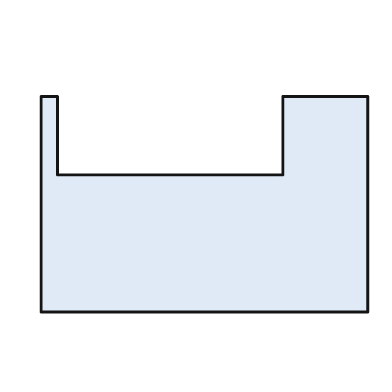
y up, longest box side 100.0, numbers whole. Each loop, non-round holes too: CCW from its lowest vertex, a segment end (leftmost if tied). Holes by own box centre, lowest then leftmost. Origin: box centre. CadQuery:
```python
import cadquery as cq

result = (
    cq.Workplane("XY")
    .moveTo(-50.0, -33.0)
    .lineTo(50.0, -33.0)
    .lineTo(50.0, 33.0)
    .lineTo(24.0, 33.0)
    .lineTo(24.0, 9.0)
    .lineTo(-45.0, 9.0)
    .lineTo(-45.0, 33.0)
    .lineTo(-50.0, 33.0)
    .close()
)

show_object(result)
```